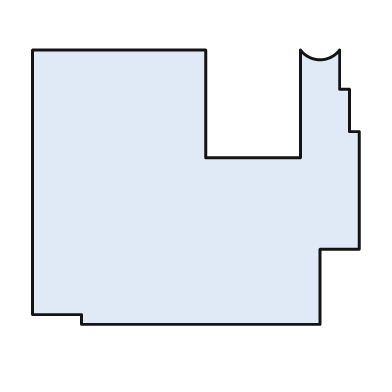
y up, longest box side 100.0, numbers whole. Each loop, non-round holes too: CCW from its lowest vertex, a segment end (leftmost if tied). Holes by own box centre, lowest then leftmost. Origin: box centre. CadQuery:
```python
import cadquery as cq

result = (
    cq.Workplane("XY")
    .moveTo(-35.0, -42.0)
    .lineTo(38.0, -42.0)
    .lineTo(38.0, -19.0)
    .lineTo(50.0, -19.0)
    .lineTo(50.0, 17.0)
    .lineTo(47.0, 17.0)
    .lineTo(47.0, 30.0)
    .lineTo(44.0, 30.0)
    .lineTo(44.0, 42.0)
    .threePointArc((38.0, 39.0), (32.0, 42.0))
    .lineTo(32.0, 9.0)
    .lineTo(3.0, 9.0)
    .lineTo(3.0, 42.0)
    .lineTo(-50.0, 42.0)
    .lineTo(-50.0, -39.0)
    .lineTo(-35.0, -39.0)
    .close()
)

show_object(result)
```